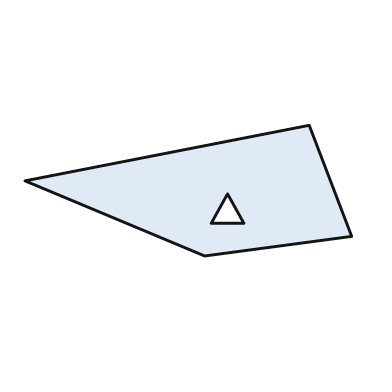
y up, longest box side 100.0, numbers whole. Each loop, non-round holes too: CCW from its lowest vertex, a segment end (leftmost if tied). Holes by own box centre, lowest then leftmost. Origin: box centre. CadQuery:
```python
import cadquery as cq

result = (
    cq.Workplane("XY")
    .moveTo(5.0, -20.0)
    .lineTo(50.0, -14.0)
    .lineTo(37.0, 20.0)
    .lineTo(-50.0, 3.0)
    .close()
    .moveTo(7.0, -10.0)
    .lineTo(17.0, -10.0)
    .lineTo(12.0, -1.0)
    .close()
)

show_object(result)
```